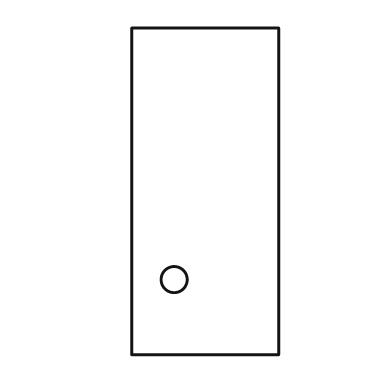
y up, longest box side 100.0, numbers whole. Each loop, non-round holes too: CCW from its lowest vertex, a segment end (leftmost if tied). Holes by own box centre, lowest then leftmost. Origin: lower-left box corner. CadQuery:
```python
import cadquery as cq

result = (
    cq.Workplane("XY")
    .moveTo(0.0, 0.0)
    .lineTo(45.0, 0.0)
    .lineTo(45.0, 100.0)
    .lineTo(0.0, 100.0)
    .close()
    .moveTo(13.0, 23.0)
    .circle(4.0)
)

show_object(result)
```